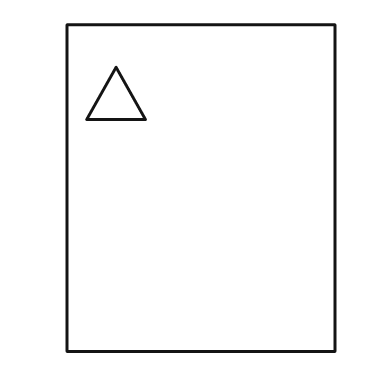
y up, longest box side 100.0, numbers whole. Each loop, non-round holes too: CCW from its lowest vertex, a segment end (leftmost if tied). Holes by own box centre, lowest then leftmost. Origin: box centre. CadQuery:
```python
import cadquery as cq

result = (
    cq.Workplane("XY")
    .moveTo(-41.0, -50.0)
    .lineTo(41.0, -50.0)
    .lineTo(41.0, 50.0)
    .lineTo(-41.0, 50.0)
    .close()
    .moveTo(-35.0, 21.0)
    .lineTo(-17.0, 21.0)
    .lineTo(-26.0, 37.0)
    .close()
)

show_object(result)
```